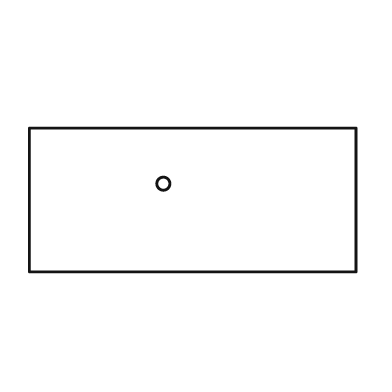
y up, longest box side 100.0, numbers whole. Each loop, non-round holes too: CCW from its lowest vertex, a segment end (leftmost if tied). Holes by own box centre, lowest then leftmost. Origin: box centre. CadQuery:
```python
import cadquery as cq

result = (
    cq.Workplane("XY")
    .moveTo(-50.0, -22.0)
    .lineTo(50.0, -22.0)
    .lineTo(50.0, 22.0)
    .lineTo(-50.0, 22.0)
    .close()
    .moveTo(-9.0, 5.0)
    .circle(2.0)
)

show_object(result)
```